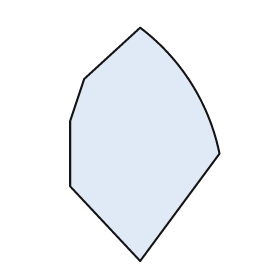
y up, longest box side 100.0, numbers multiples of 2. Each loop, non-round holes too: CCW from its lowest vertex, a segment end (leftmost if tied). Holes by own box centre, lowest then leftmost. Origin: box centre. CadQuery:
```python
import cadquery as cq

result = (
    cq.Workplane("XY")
    .moveTo(-2.0, -50.0)
    .lineTo(32.0, -4.0)
    .threePointArc((20.0, 26.0), (-2.0, 50.0))
    .lineTo(-26.0, 28.0)
    .lineTo(-32.0, 10.0)
    .lineTo(-32.0, -18.0)
    .close()
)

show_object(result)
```